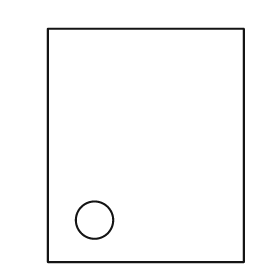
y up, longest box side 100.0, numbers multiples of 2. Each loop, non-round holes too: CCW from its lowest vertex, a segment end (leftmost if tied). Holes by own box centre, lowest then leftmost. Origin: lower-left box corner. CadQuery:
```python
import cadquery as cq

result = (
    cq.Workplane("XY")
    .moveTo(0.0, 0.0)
    .lineTo(84.0, 0.0)
    .lineTo(84.0, 100.0)
    .lineTo(0.0, 100.0)
    .close()
    .moveTo(20.0, 18.0)
    .circle(8.0)
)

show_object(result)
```